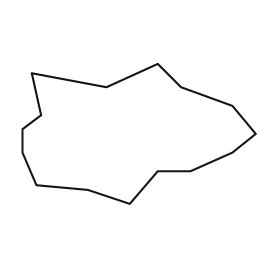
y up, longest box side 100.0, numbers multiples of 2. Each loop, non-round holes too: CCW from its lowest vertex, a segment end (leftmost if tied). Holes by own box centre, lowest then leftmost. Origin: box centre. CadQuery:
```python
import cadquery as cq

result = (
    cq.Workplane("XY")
    .moveTo(-4.0, -30.0)
    .lineTo(8.0, -16.0)
    .lineTo(22.0, -16.0)
    .lineTo(40.0, -8.0)
    .lineTo(50.0, 0.0)
    .lineTo(40.0, 12.0)
    .lineTo(18.0, 20.0)
    .lineTo(8.0, 30.0)
    .lineTo(-14.0, 20.0)
    .lineTo(-46.0, 26.0)
    .lineTo(-42.0, 8.0)
    .lineTo(-50.0, 2.0)
    .lineTo(-50.0, -8.0)
    .lineTo(-44.0, -22.0)
    .lineTo(-22.0, -24.0)
    .close()
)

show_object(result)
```